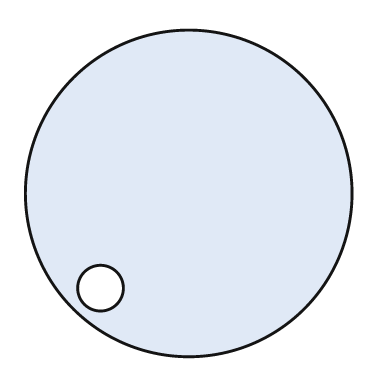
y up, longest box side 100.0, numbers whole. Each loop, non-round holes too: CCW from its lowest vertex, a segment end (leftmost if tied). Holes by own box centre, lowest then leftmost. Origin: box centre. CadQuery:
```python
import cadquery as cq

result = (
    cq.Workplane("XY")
    .moveTo(0.0, 0.0)
    .circle(50.0)
    .moveTo(-27.0, -29.0)
    .circle(7.0)
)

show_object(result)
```